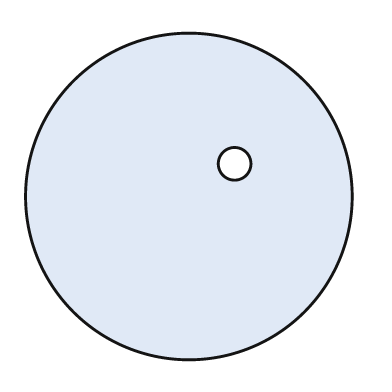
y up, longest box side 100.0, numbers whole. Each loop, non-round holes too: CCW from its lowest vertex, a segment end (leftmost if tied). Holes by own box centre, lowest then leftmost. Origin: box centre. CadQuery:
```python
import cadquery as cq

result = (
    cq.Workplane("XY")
    .moveTo(0.0, 0.0)
    .circle(50.0)
    .moveTo(14.0, 10.0)
    .circle(5.0)
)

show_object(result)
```